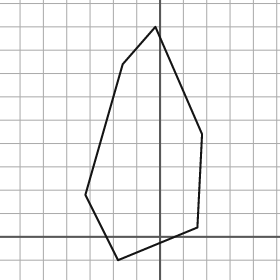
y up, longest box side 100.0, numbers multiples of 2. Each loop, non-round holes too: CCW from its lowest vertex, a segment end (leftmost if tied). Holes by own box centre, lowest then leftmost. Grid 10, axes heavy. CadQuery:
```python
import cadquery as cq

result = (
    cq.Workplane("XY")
    .moveTo(-18.0, -10.0)
    .lineTo(16.0, 4.0)
    .lineTo(18.0, 44.0)
    .lineTo(-2.0, 90.0)
    .lineTo(-16.0, 74.0)
    .lineTo(-32.0, 18.0)
    .close()
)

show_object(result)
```